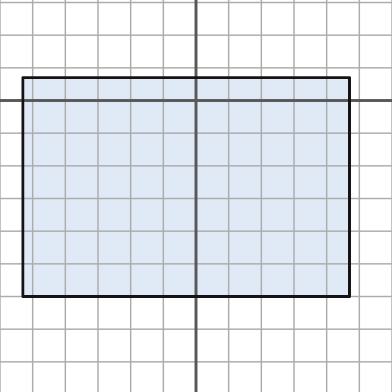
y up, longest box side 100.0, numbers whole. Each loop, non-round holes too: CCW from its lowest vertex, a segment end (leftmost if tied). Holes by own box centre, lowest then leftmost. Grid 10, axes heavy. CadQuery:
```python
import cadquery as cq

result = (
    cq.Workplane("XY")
    .moveTo(-53.0, -60.0)
    .lineTo(47.0, -60.0)
    .lineTo(47.0, 7.0)
    .lineTo(-53.0, 7.0)
    .close()
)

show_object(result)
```